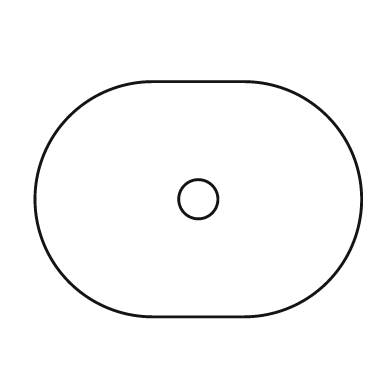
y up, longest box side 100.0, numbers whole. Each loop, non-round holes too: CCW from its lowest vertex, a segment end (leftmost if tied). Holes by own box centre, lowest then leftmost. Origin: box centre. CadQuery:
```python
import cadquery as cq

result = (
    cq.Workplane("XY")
    .moveTo(-14.0, -36.0)
    .lineTo(14.0, -36.0)
    .threePointArc((50.0, 0.0), (14.0, 36.0))
    .lineTo(-14.0, 36.0)
    .threePointArc((-50.0, 0.0), (-14.0, -36.0))
    .close()
    .moveTo(0.0, 0.0)
    .circle(6.0)
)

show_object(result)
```